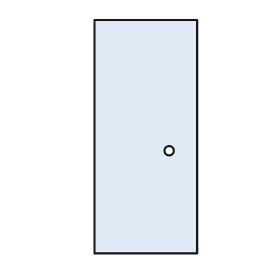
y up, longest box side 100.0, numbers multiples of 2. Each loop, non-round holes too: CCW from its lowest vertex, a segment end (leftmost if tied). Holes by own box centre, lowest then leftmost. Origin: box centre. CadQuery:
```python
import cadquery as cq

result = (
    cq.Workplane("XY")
    .moveTo(-22.0, -50.0)
    .lineTo(22.0, -50.0)
    .lineTo(22.0, 50.0)
    .lineTo(-22.0, 50.0)
    .close()
    .moveTo(10.0, -6.0)
    .circle(2.0)
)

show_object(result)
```